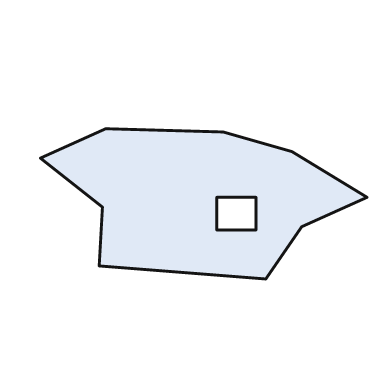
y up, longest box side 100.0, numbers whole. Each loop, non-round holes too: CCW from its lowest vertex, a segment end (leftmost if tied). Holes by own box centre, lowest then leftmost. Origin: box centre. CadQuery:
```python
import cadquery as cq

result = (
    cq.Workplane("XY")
    .moveTo(19.0, -23.0)
    .lineTo(30.0, -7.0)
    .lineTo(50.0, 2.0)
    .lineTo(27.0, 16.0)
    .lineTo(6.0, 22.0)
    .lineTo(-30.0, 23.0)
    .lineTo(-50.0, 14.0)
    .lineTo(-31.0, -1.0)
    .lineTo(-32.0, -19.0)
    .close()
    .moveTo(4.0, -8.0)
    .lineTo(16.0, -8.0)
    .lineTo(16.0, 2.0)
    .lineTo(4.0, 2.0)
    .close()
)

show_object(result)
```